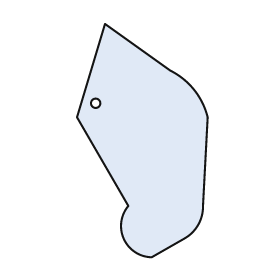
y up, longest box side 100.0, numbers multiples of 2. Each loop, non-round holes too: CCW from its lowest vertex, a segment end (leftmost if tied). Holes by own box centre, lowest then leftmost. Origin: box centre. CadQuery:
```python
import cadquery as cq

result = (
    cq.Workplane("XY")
    .moveTo(4.0, -50.0)
    .lineTo(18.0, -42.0)
    .threePointArc((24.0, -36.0), (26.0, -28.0))
    .lineTo(28.0, 10.0)
    .threePointArc((22.0, 22.0), (12.0, 30.0))
    .lineTo(-16.0, 50.0)
    .lineTo(-28.0, 10.0)
    .lineTo(-6.0, -28.0)
    .threePointArc((-8.0, -42.0), (4.0, -50.0))
    .close()
    .moveTo(-20.0, 16.0)
    .circle(2.0)
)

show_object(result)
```